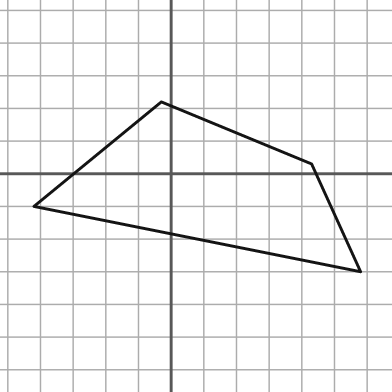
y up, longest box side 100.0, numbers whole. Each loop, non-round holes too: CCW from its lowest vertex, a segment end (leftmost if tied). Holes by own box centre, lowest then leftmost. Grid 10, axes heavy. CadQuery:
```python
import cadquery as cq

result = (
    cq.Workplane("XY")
    .moveTo(58.0, -30.0)
    .lineTo(43.0, 3.0)
    .lineTo(-3.0, 22.0)
    .lineTo(-42.0, -10.0)
    .close()
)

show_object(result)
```